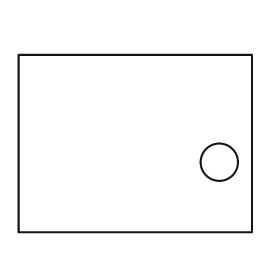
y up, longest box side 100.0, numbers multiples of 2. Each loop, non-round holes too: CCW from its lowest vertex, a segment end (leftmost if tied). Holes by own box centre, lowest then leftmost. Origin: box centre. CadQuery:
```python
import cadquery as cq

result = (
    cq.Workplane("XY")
    .moveTo(-50.0, -38.0)
    .lineTo(50.0, -38.0)
    .lineTo(50.0, 38.0)
    .lineTo(-50.0, 38.0)
    .close()
    .moveTo(36.0, -8.0)
    .circle(8.0)
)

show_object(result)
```